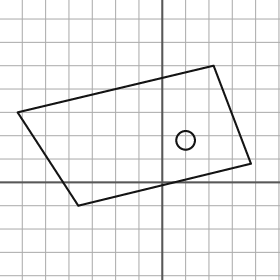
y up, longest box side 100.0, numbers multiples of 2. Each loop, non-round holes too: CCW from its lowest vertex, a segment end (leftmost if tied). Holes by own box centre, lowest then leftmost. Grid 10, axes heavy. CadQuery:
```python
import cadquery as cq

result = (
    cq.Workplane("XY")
    .moveTo(-36.0, -10.0)
    .lineTo(38.0, 8.0)
    .lineTo(22.0, 50.0)
    .lineTo(-62.0, 30.0)
    .close()
    .moveTo(10.0, 18.0)
    .circle(4.0)
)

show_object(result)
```